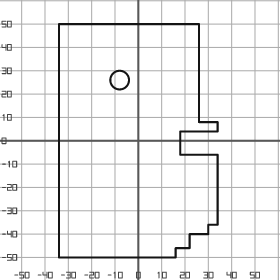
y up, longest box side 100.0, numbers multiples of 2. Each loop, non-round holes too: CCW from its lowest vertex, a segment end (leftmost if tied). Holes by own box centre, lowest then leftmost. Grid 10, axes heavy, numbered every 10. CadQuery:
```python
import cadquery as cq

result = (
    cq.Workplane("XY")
    .moveTo(-34.0, -50.0)
    .lineTo(16.0, -50.0)
    .lineTo(16.0, -46.0)
    .lineTo(22.0, -46.0)
    .lineTo(22.0, -40.0)
    .lineTo(30.0, -40.0)
    .lineTo(30.0, -36.0)
    .lineTo(34.0, -36.0)
    .lineTo(34.0, -6.0)
    .lineTo(18.0, -6.0)
    .lineTo(18.0, 4.0)
    .lineTo(34.0, 4.0)
    .lineTo(34.0, 8.0)
    .lineTo(26.0, 8.0)
    .lineTo(26.0, 50.0)
    .lineTo(-34.0, 50.0)
    .close()
    .moveTo(-8.0, 26.0)
    .circle(4.0)
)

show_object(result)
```